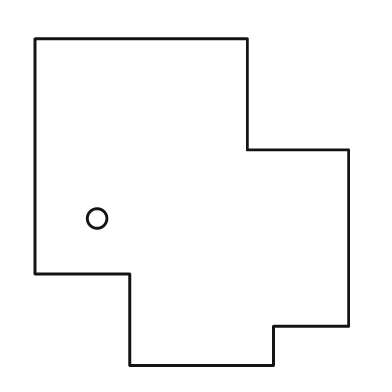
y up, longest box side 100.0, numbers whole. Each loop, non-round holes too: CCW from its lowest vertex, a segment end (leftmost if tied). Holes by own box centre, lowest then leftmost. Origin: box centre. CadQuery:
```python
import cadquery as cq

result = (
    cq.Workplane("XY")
    .moveTo(-19.0, -50.0)
    .lineTo(25.0, -50.0)
    .lineTo(25.0, -38.0)
    .lineTo(48.0, -38.0)
    .lineTo(48.0, 16.0)
    .lineTo(17.0, 16.0)
    .lineTo(17.0, 50.0)
    .lineTo(-48.0, 50.0)
    .lineTo(-48.0, -22.0)
    .lineTo(-19.0, -22.0)
    .close()
    .moveTo(-29.0, -5.0)
    .circle(3.0)
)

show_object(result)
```